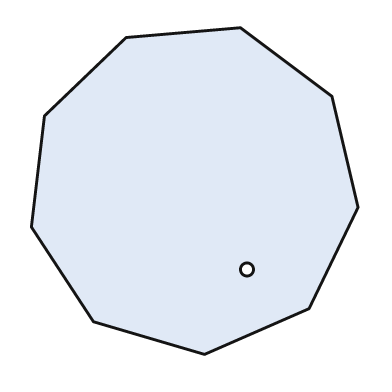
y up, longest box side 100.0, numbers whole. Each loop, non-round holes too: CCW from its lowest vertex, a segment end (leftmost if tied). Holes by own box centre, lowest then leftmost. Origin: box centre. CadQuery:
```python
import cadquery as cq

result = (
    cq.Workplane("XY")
    .moveTo(3.0, -50.0)
    .lineTo(35.0, -36.0)
    .lineTo(50.0, -5.0)
    .lineTo(42.0, 29.0)
    .lineTo(14.0, 50.0)
    .lineTo(-21.0, 47.0)
    .lineTo(-46.0, 23.0)
    .lineTo(-50.0, -11.0)
    .lineTo(-31.0, -40.0)
    .close()
    .moveTo(16.0, -24.0)
    .circle(2.0)
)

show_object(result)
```